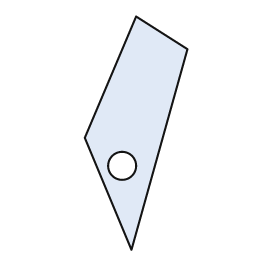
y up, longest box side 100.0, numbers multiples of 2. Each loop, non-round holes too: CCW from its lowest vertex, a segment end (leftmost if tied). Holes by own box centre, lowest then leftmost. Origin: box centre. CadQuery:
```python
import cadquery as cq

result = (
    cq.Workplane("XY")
    .moveTo(-2.0, -50.0)
    .lineTo(22.0, 36.0)
    .lineTo(0.0, 50.0)
    .lineTo(-22.0, -2.0)
    .close()
    .moveTo(-6.0, -14.0)
    .circle(6.0)
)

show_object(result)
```